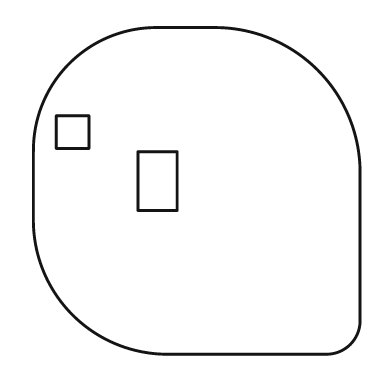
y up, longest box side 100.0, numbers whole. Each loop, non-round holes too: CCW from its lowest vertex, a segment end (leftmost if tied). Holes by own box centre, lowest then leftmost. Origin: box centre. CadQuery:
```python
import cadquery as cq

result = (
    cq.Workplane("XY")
    .moveTo(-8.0, -50.0)
    .lineTo(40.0, -50.0)
    .threePointArc((47.0, -47.0), (50.0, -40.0))
    .lineTo(50.0, 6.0)
    .threePointArc((37.0, 37.0), (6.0, 50.0))
    .lineTo(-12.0, 50.0)
    .threePointArc((-39.0, 39.0), (-50.0, 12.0))
    .lineTo(-50.0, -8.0)
    .threePointArc((-38.0, -38.0), (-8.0, -50.0))
    .close()
    .moveTo(-18.0, -6.0)
    .lineTo(-6.0, -6.0)
    .lineTo(-6.0, 12.0)
    .lineTo(-18.0, 12.0)
    .close()
    .moveTo(-43.0, 13.0)
    .lineTo(-33.0, 13.0)
    .lineTo(-33.0, 23.0)
    .lineTo(-43.0, 23.0)
    .close()
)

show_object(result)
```